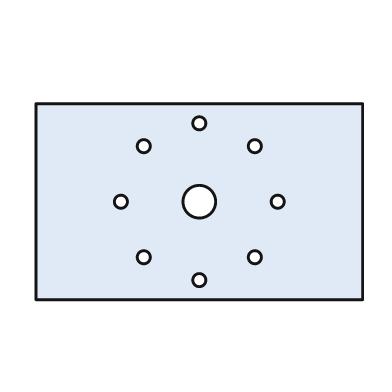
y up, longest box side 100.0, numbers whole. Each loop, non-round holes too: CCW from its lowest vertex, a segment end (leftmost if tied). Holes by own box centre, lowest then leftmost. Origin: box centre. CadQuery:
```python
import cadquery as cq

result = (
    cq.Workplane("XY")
    .moveTo(-50.0, -30.0)
    .lineTo(50.0, -30.0)
    .lineTo(50.0, 30.0)
    .lineTo(-50.0, 30.0)
    .close()
    .moveTo(0.0, -24.0)
    .circle(2.0)
    .moveTo(-17.0, -17.0)
    .circle(2.0)
    .moveTo(17.0, -17.0)
    .circle(2.0)
    .moveTo(-24.0, 0.0)
    .circle(2.0)
    .moveTo(0.0, 0.0)
    .circle(5.0)
    .moveTo(24.0, 0.0)
    .circle(2.0)
    .moveTo(-17.0, 17.0)
    .circle(2.0)
    .moveTo(17.0, 17.0)
    .circle(2.0)
    .moveTo(0.0, 24.0)
    .circle(2.0)
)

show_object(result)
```